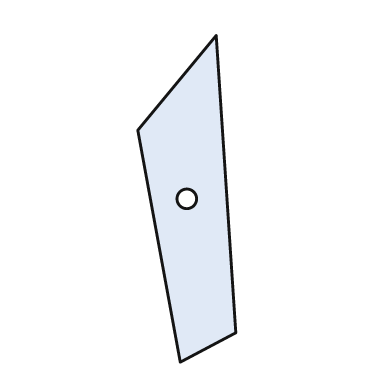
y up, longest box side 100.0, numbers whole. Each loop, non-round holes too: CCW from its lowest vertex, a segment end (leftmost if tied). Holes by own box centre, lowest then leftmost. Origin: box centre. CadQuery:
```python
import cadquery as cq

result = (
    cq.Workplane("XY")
    .moveTo(-2.0, -50.0)
    .lineTo(15.0, -41.0)
    .lineTo(9.0, 50.0)
    .lineTo(-15.0, 21.0)
    .close()
    .moveTo(0.0, 0.0)
    .circle(3.0)
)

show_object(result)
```